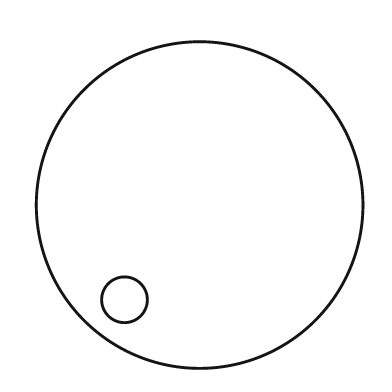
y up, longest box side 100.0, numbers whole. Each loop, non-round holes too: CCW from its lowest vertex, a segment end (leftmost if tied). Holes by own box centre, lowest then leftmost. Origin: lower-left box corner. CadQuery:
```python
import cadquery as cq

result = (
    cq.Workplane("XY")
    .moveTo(50.0, 50.0)
    .circle(50.0)
    .moveTo(27.0, 21.0)
    .circle(7.0)
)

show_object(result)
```